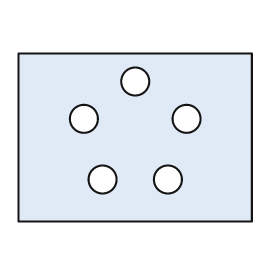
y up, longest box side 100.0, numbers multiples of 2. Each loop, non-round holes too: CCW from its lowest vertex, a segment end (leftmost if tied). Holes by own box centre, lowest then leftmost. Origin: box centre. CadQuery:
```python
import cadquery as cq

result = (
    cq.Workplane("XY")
    .moveTo(-50.0, -36.0)
    .lineTo(50.0, -36.0)
    .lineTo(50.0, 36.0)
    .lineTo(-50.0, 36.0)
    .close()
    .moveTo(-14.0, -18.0)
    .circle(6.0)
    .moveTo(14.0, -18.0)
    .circle(6.0)
    .moveTo(-22.0, 8.0)
    .circle(6.0)
    .moveTo(22.0, 8.0)
    .circle(6.0)
    .moveTo(0.0, 24.0)
    .circle(6.0)
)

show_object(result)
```